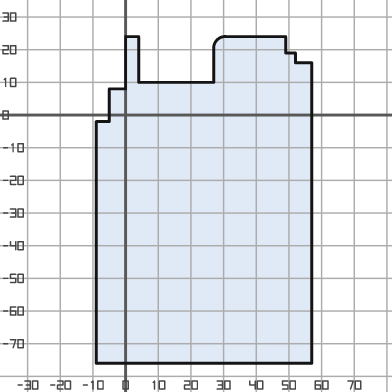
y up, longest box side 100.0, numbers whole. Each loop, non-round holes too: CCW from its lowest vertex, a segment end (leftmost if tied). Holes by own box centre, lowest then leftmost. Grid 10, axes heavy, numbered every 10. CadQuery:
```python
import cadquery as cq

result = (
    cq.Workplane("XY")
    .moveTo(-9.0, -76.0)
    .lineTo(57.0, -76.0)
    .lineTo(57.0, 16.0)
    .lineTo(52.0, 16.0)
    .lineTo(52.0, 19.0)
    .lineTo(49.0, 19.0)
    .lineTo(49.0, 24.0)
    .lineTo(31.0, 24.0)
    .threePointArc((28.0, 23.0), (27.0, 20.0))
    .lineTo(27.0, 10.0)
    .lineTo(4.0, 10.0)
    .lineTo(4.0, 24.0)
    .lineTo(0.0, 24.0)
    .lineTo(0.0, 8.0)
    .lineTo(-5.0, 8.0)
    .lineTo(-5.0, -2.0)
    .lineTo(-9.0, -2.0)
    .close()
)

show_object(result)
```